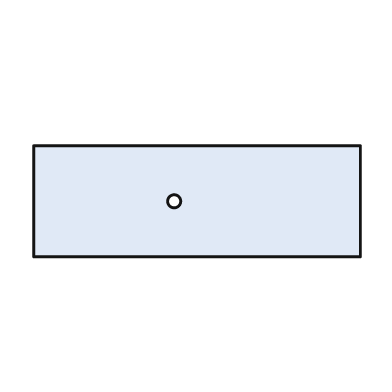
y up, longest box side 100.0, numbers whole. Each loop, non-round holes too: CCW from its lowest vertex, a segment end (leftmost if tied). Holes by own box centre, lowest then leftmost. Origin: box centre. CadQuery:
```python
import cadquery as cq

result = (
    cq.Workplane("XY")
    .moveTo(-50.0, -17.0)
    .lineTo(50.0, -17.0)
    .lineTo(50.0, 17.0)
    .lineTo(-50.0, 17.0)
    .close()
    .moveTo(-7.0, 0.0)
    .circle(2.0)
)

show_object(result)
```